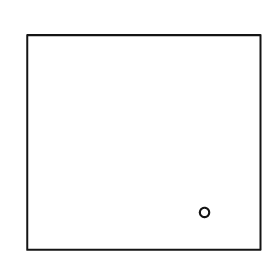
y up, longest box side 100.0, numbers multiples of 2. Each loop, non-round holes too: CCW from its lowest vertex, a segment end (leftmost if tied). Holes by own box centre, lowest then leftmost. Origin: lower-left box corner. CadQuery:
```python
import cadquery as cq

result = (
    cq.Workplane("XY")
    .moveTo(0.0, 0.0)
    .lineTo(100.0, 0.0)
    .lineTo(100.0, 92.0)
    .lineTo(0.0, 92.0)
    .close()
    .moveTo(76.0, 16.0)
    .circle(2.0)
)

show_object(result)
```